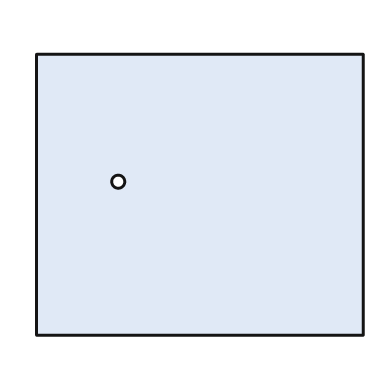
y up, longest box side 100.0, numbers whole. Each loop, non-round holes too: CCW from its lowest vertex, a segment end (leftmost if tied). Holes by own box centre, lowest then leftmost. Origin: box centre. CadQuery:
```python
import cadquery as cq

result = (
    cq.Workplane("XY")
    .moveTo(-50.0, -43.0)
    .lineTo(50.0, -43.0)
    .lineTo(50.0, 43.0)
    .lineTo(-50.0, 43.0)
    .close()
    .moveTo(-25.0, 4.0)
    .circle(2.0)
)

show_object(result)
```